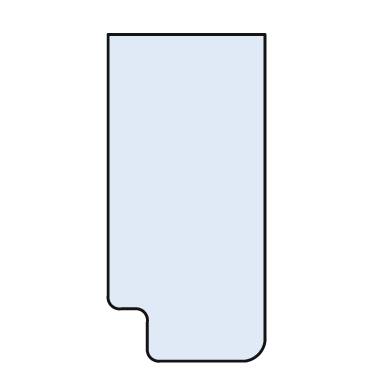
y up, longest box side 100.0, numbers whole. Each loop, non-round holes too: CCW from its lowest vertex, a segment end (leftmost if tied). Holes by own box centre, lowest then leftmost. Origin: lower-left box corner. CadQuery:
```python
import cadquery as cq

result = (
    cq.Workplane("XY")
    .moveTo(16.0, 0.0)
    .lineTo(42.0, 0.0)
    .threePointArc((46.0, 2.0), (48.0, 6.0))
    .lineTo(48.0, 100.0)
    .lineTo(0.0, 100.0)
    .lineTo(0.0, 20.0)
    .threePointArc((1.0, 17.0), (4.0, 16.0))
    .lineTo(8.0, 16.0)
    .threePointArc((11.0, 15.0), (12.0, 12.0))
    .lineTo(12.0, 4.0)
    .threePointArc((13.0, 1.0), (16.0, 0.0))
    .close()
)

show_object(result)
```